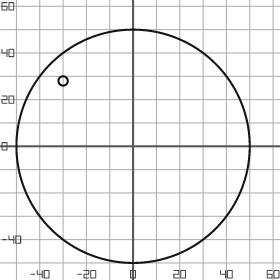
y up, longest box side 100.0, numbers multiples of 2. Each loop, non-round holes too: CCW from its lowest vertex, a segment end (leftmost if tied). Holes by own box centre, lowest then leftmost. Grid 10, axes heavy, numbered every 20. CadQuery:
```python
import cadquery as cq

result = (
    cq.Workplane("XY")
    .moveTo(0.0, 0.0)
    .circle(50.0)
    .moveTo(-30.0, 28.0)
    .circle(2.0)
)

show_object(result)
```